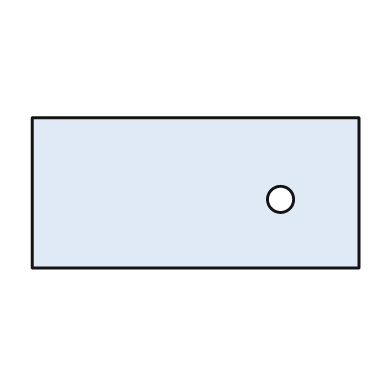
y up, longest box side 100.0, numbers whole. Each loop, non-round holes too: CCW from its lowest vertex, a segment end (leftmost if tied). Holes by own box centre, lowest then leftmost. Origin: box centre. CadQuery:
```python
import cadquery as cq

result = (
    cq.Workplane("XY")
    .moveTo(-50.0, -23.0)
    .lineTo(50.0, -23.0)
    .lineTo(50.0, 23.0)
    .lineTo(-50.0, 23.0)
    .close()
    .moveTo(26.0, -2.0)
    .circle(4.0)
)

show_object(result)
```